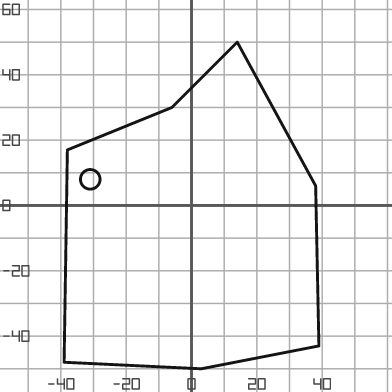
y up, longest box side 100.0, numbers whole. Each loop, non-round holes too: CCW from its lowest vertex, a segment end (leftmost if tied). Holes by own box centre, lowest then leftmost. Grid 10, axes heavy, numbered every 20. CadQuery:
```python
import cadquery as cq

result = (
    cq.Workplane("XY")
    .moveTo(3.0, -50.0)
    .lineTo(39.0, -43.0)
    .lineTo(38.0, 6.0)
    .lineTo(14.0, 50.0)
    .lineTo(-6.0, 30.0)
    .lineTo(-38.0, 17.0)
    .lineTo(-39.0, -48.0)
    .close()
    .moveTo(-31.0, 8.0)
    .circle(3.0)
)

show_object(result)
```